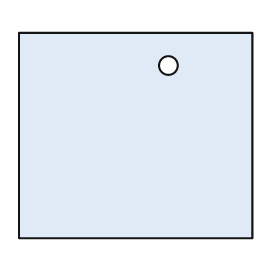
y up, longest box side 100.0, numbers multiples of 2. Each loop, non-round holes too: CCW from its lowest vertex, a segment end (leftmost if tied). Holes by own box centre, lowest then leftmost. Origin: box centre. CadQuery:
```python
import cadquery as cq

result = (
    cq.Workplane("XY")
    .moveTo(-50.0, -44.0)
    .lineTo(50.0, -44.0)
    .lineTo(50.0, 44.0)
    .lineTo(-50.0, 44.0)
    .close()
    .moveTo(14.0, 30.0)
    .circle(4.0)
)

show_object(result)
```